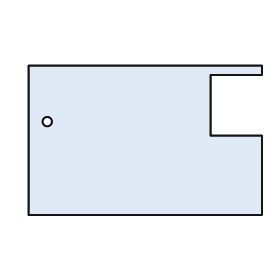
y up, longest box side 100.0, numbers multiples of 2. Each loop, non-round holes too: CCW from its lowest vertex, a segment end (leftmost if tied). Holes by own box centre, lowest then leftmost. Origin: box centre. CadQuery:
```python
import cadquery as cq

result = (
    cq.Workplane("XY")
    .moveTo(-50.0, -32.0)
    .lineTo(50.0, -32.0)
    .lineTo(50.0, 2.0)
    .lineTo(28.0, 2.0)
    .lineTo(28.0, 28.0)
    .lineTo(50.0, 28.0)
    .lineTo(50.0, 32.0)
    .lineTo(-50.0, 32.0)
    .close()
    .moveTo(-42.0, 8.0)
    .circle(2.0)
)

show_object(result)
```